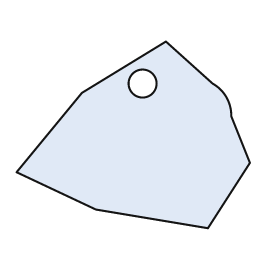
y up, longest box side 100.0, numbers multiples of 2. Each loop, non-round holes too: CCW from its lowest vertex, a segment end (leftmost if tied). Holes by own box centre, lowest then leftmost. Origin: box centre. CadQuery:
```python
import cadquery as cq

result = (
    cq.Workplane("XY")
    .moveTo(32.0, -40.0)
    .lineTo(50.0, -12.0)
    .lineTo(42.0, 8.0)
    .threePointArc((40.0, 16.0), (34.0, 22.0))
    .lineTo(14.0, 40.0)
    .lineTo(-22.0, 18.0)
    .lineTo(-50.0, -16.0)
    .lineTo(-16.0, -32.0)
    .close()
    .moveTo(4.0, 22.0)
    .circle(6.0)
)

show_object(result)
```